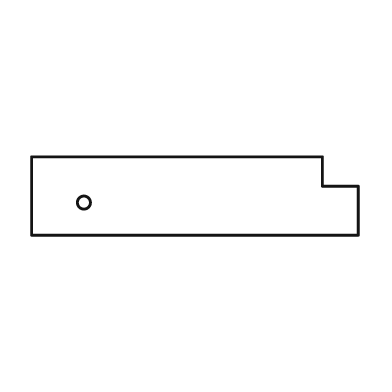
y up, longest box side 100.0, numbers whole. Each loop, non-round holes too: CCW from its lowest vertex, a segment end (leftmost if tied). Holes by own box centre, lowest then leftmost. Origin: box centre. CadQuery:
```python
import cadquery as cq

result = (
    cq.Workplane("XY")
    .moveTo(-50.0, -12.0)
    .lineTo(50.0, -12.0)
    .lineTo(50.0, 3.0)
    .lineTo(39.0, 3.0)
    .lineTo(39.0, 12.0)
    .lineTo(-50.0, 12.0)
    .close()
    .moveTo(-34.0, -2.0)
    .circle(2.0)
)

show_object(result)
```